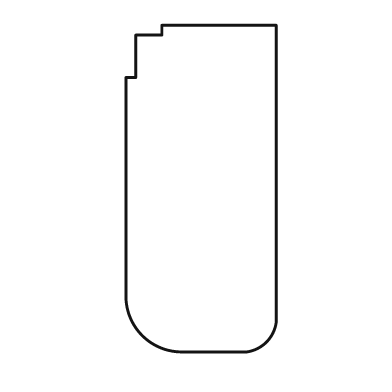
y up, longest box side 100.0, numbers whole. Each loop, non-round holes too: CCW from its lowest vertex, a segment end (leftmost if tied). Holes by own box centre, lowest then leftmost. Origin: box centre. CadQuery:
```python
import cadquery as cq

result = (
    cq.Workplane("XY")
    .moveTo(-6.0, -50.0)
    .lineTo(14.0, -50.0)
    .threePointArc((20.0, -47.0), (23.0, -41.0))
    .lineTo(23.0, 50.0)
    .lineTo(-12.0, 50.0)
    .lineTo(-12.0, 47.0)
    .lineTo(-20.0, 47.0)
    .lineTo(-20.0, 34.0)
    .lineTo(-23.0, 34.0)
    .lineTo(-23.0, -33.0)
    .threePointArc((-18.0, -45.0), (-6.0, -50.0))
    .close()
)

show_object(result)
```